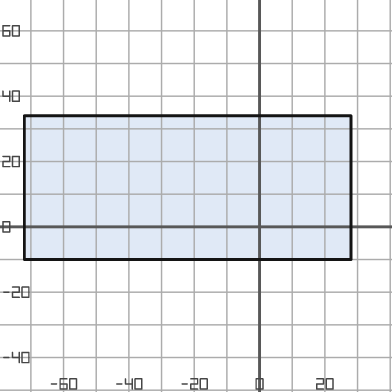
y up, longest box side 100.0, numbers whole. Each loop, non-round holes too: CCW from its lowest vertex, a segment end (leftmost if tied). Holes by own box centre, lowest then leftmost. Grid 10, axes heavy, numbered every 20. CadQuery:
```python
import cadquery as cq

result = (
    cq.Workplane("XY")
    .moveTo(-72.0, -10.0)
    .lineTo(28.0, -10.0)
    .lineTo(28.0, 34.0)
    .lineTo(-72.0, 34.0)
    .close()
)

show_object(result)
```